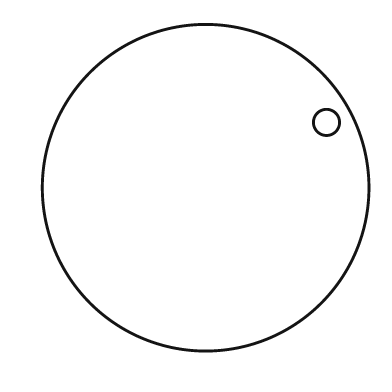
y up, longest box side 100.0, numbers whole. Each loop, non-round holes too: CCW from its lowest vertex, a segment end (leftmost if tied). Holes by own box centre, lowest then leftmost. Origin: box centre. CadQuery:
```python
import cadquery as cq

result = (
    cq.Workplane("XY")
    .moveTo(0.0, 0.0)
    .circle(50.0)
    .moveTo(37.0, 20.0)
    .circle(4.0)
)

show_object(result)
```